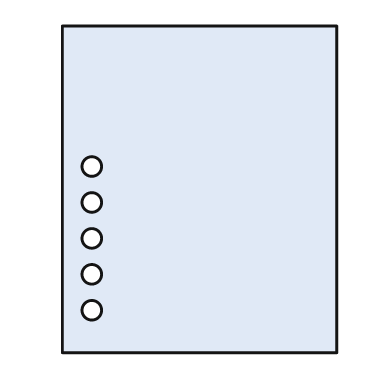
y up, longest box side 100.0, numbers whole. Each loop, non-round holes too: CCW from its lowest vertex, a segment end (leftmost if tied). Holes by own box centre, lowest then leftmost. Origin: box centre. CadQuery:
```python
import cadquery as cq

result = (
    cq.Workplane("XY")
    .moveTo(-42.0, -50.0)
    .lineTo(42.0, -50.0)
    .lineTo(42.0, 50.0)
    .lineTo(-42.0, 50.0)
    .close()
    .moveTo(-33.0, -37.0)
    .circle(3.0)
    .moveTo(-33.0, -26.0)
    .circle(3.0)
    .moveTo(-33.0, -15.0)
    .circle(3.0)
    .moveTo(-33.0, -4.0)
    .circle(3.0)
    .moveTo(-33.0, 7.0)
    .circle(3.0)
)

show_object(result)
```